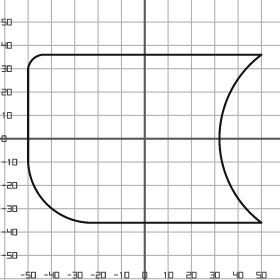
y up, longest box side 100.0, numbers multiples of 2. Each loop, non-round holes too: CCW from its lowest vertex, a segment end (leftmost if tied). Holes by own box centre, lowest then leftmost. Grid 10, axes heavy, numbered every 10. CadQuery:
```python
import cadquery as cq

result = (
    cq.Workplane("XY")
    .moveTo(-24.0, -36.0)
    .lineTo(50.0, -36.0)
    .threePointArc((32.0, 0.0), (50.0, 36.0))
    .lineTo(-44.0, 36.0)
    .threePointArc((-48.0, 34.0), (-50.0, 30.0))
    .lineTo(-50.0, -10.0)
    .threePointArc((-42.0, -28.0), (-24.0, -36.0))
    .close()
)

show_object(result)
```